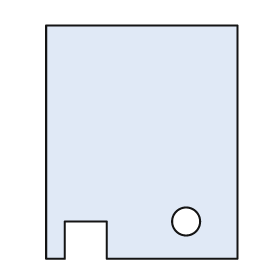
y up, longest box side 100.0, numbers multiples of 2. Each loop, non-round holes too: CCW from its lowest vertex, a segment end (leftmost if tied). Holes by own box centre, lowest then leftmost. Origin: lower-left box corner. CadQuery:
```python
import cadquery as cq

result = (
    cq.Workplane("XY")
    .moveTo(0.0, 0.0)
    .lineTo(8.0, 0.0)
    .lineTo(8.0, 16.0)
    .lineTo(26.0, 16.0)
    .lineTo(26.0, 0.0)
    .lineTo(82.0, 0.0)
    .lineTo(82.0, 100.0)
    .lineTo(0.0, 100.0)
    .close()
    .moveTo(60.0, 16.0)
    .circle(6.0)
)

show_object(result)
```